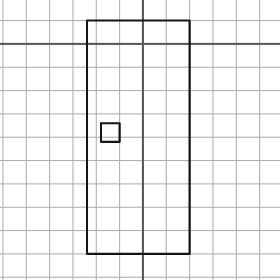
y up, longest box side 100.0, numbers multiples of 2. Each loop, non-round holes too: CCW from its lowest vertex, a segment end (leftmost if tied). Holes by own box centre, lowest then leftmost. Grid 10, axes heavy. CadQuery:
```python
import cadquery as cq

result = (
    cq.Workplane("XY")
    .moveTo(-24.0, -90.0)
    .lineTo(20.0, -90.0)
    .lineTo(20.0, 10.0)
    .lineTo(-24.0, 10.0)
    .close()
    .moveTo(-18.0, -42.0)
    .lineTo(-10.0, -42.0)
    .lineTo(-10.0, -34.0)
    .lineTo(-18.0, -34.0)
    .close()
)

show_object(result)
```